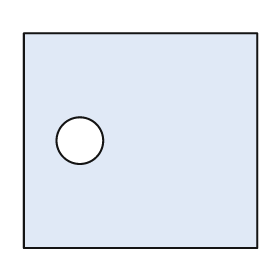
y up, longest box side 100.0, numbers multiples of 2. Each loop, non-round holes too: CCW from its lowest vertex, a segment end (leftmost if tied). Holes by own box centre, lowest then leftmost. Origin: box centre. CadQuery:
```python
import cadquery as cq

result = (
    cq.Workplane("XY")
    .moveTo(-50.0, -46.0)
    .lineTo(50.0, -46.0)
    .lineTo(50.0, 46.0)
    .lineTo(-50.0, 46.0)
    .close()
    .moveTo(-26.0, 0.0)
    .circle(10.0)
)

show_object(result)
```